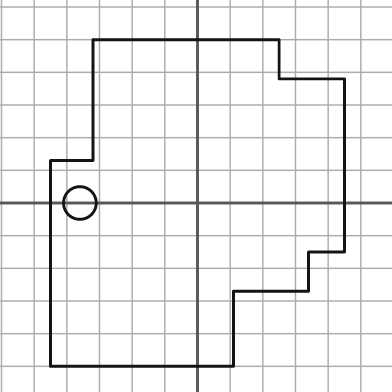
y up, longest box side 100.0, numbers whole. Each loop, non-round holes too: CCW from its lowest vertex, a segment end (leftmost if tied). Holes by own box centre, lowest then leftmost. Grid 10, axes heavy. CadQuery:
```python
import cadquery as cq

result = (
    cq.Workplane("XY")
    .moveTo(-45.0, -50.0)
    .lineTo(11.0, -50.0)
    .lineTo(11.0, -27.0)
    .lineTo(34.0, -27.0)
    .lineTo(34.0, -15.0)
    .lineTo(45.0, -15.0)
    .lineTo(45.0, 38.0)
    .lineTo(25.0, 38.0)
    .lineTo(25.0, 50.0)
    .lineTo(-32.0, 50.0)
    .lineTo(-32.0, 13.0)
    .lineTo(-45.0, 13.0)
    .close()
    .moveTo(-36.0, 0.0)
    .circle(5.0)
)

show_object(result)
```